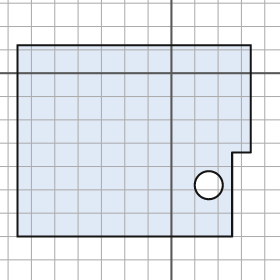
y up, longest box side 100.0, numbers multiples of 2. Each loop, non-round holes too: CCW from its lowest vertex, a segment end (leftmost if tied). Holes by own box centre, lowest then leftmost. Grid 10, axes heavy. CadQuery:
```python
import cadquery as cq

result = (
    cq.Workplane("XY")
    .moveTo(-66.0, -70.0)
    .lineTo(26.0, -70.0)
    .lineTo(26.0, -34.0)
    .lineTo(34.0, -34.0)
    .lineTo(34.0, 12.0)
    .lineTo(-66.0, 12.0)
    .close()
    .moveTo(16.0, -48.0)
    .circle(6.0)
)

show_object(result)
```